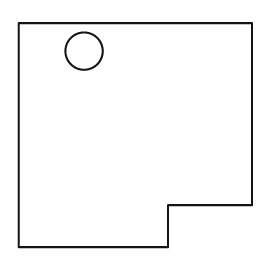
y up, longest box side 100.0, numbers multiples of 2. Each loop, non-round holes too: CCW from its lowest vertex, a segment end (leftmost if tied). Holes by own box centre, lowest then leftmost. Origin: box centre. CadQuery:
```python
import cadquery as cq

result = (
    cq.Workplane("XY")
    .moveTo(-50.0, -48.0)
    .lineTo(14.0, -48.0)
    .lineTo(14.0, -30.0)
    .lineTo(50.0, -30.0)
    .lineTo(50.0, 48.0)
    .lineTo(-50.0, 48.0)
    .close()
    .moveTo(-22.0, 36.0)
    .circle(8.0)
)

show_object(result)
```